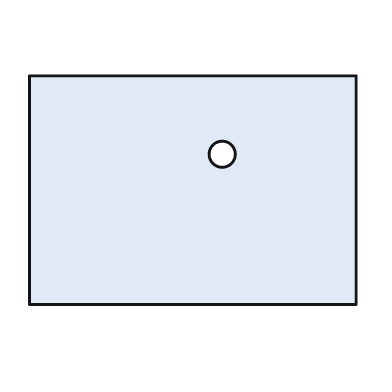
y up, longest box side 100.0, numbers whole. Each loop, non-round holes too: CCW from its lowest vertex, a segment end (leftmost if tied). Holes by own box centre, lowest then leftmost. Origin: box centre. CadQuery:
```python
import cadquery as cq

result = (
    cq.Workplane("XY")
    .moveTo(-50.0, -35.0)
    .lineTo(50.0, -35.0)
    .lineTo(50.0, 35.0)
    .lineTo(-50.0, 35.0)
    .close()
    .moveTo(9.0, 11.0)
    .circle(4.0)
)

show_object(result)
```